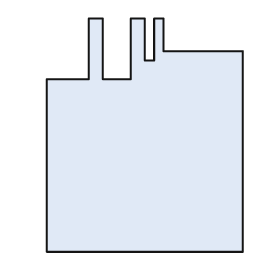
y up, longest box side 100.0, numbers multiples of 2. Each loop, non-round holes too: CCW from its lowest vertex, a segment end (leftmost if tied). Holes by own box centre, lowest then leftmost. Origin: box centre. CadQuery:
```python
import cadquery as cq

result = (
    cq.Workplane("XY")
    .moveTo(-42.0, -50.0)
    .lineTo(42.0, -50.0)
    .lineTo(42.0, 36.0)
    .lineTo(8.0, 36.0)
    .lineTo(8.0, 50.0)
    .lineTo(4.0, 50.0)
    .lineTo(4.0, 32.0)
    .lineTo(0.0, 32.0)
    .lineTo(0.0, 50.0)
    .lineTo(-6.0, 50.0)
    .lineTo(-6.0, 24.0)
    .lineTo(-18.0, 24.0)
    .lineTo(-18.0, 50.0)
    .lineTo(-24.0, 50.0)
    .lineTo(-24.0, 24.0)
    .lineTo(-42.0, 24.0)
    .close()
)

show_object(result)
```